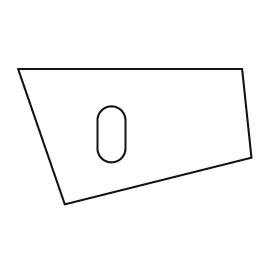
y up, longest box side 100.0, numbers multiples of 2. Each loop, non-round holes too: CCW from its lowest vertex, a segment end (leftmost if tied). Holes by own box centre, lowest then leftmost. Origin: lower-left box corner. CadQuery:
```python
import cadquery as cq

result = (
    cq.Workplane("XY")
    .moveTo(20.0, 0.0)
    .lineTo(100.0, 20.0)
    .lineTo(96.0, 58.0)
    .lineTo(0.0, 58.0)
    .close()
    .moveTo(34.0, 24.0)
    .threePointArc((40.0, 18.0), (46.0, 24.0))
    .lineTo(46.0, 36.0)
    .threePointArc((40.0, 42.0), (34.0, 36.0))
    .close()
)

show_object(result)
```